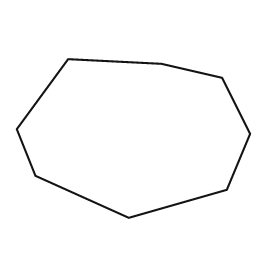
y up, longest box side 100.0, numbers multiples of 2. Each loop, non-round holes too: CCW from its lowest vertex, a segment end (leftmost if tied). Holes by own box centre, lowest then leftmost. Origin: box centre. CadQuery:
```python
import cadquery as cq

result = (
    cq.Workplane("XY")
    .moveTo(-2.0, -34.0)
    .lineTo(40.0, -22.0)
    .lineTo(50.0, 2.0)
    .lineTo(38.0, 26.0)
    .lineTo(12.0, 32.0)
    .lineTo(-28.0, 34.0)
    .lineTo(-50.0, 4.0)
    .lineTo(-42.0, -16.0)
    .close()
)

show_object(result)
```